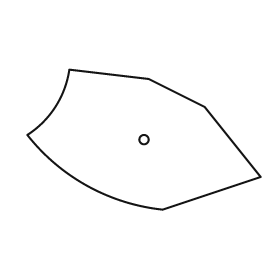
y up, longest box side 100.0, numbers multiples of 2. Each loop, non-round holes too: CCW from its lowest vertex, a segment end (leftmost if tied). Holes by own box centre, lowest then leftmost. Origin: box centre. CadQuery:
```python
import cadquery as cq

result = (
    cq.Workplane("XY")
    .moveTo(8.0, -30.0)
    .lineTo(50.0, -16.0)
    .lineTo(26.0, 14.0)
    .lineTo(2.0, 26.0)
    .lineTo(-32.0, 30.0)
    .threePointArc((-38.0, 14.0), (-50.0, 2.0))
    .threePointArc((-24.0, -20.0), (8.0, -30.0))
    .close()
    .moveTo(0.0, 0.0)
    .circle(2.0)
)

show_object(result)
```